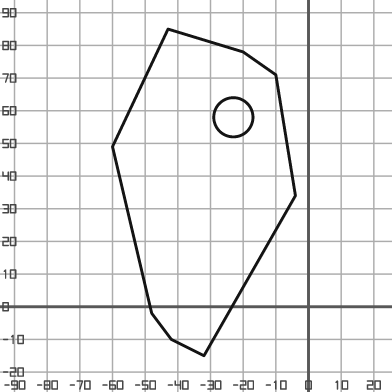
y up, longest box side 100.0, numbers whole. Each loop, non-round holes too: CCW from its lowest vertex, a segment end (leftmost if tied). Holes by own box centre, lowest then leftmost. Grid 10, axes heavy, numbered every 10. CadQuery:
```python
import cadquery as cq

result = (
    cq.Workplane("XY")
    .moveTo(-32.0, -15.0)
    .lineTo(-4.0, 34.0)
    .lineTo(-10.0, 71.0)
    .lineTo(-20.0, 78.0)
    .lineTo(-43.0, 85.0)
    .lineTo(-60.0, 49.0)
    .lineTo(-48.0, -2.0)
    .lineTo(-42.0, -10.0)
    .close()
    .moveTo(-23.0, 58.0)
    .circle(6.0)
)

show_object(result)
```